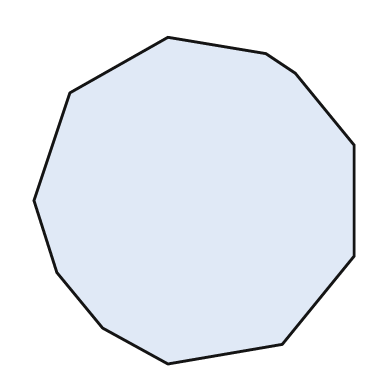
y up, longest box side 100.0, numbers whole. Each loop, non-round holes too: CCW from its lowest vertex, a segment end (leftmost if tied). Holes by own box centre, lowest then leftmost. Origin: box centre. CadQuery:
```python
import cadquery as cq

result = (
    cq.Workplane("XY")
    .moveTo(-8.0, -50.0)
    .lineTo(27.0, -44.0)
    .lineTo(49.0, -17.0)
    .lineTo(49.0, 17.0)
    .lineTo(31.0, 39.0)
    .lineTo(22.0, 45.0)
    .lineTo(-8.0, 50.0)
    .lineTo(-38.0, 33.0)
    .lineTo(-49.0, 0.0)
    .lineTo(-42.0, -22.0)
    .lineTo(-28.0, -39.0)
    .close()
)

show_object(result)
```